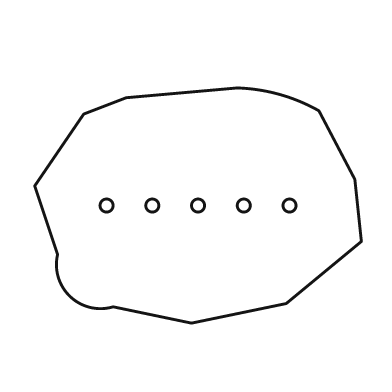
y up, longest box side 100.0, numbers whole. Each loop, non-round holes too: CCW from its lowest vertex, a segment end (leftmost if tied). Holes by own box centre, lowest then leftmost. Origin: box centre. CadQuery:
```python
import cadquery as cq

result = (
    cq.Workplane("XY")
    .moveTo(-2.0, -36.0)
    .lineTo(27.0, -30.0)
    .lineTo(50.0, -11.0)
    .lineTo(48.0, 8.0)
    .lineTo(37.0, 29.0)
    .threePointArc((25.0, 34.0), (12.0, 36.0))
    .lineTo(-22.0, 33.0)
    .lineTo(-35.0, 28.0)
    .lineTo(-50.0, 6.0)
    .lineTo(-43.0, -15.0)
    .threePointArc((-39.0, -28.0), (-26.0, -31.0))
    .close()
    .moveTo(-28.0, 0.0)
    .circle(2.0)
    .moveTo(-14.0, 0.0)
    .circle(2.0)
    .moveTo(0.0, 0.0)
    .circle(2.0)
    .moveTo(14.0, 0.0)
    .circle(2.0)
    .moveTo(28.0, 0.0)
    .circle(2.0)
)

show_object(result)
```